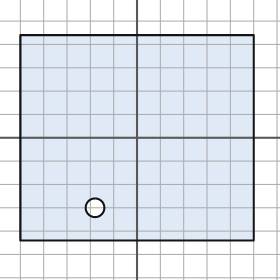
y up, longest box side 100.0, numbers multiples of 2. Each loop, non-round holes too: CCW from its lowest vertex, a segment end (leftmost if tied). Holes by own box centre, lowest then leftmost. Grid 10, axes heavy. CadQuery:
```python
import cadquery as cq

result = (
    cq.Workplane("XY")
    .moveTo(-50.0, -44.0)
    .lineTo(50.0, -44.0)
    .lineTo(50.0, 44.0)
    .lineTo(-50.0, 44.0)
    .close()
    .moveTo(-18.0, -30.0)
    .circle(4.0)
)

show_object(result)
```